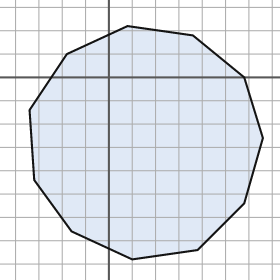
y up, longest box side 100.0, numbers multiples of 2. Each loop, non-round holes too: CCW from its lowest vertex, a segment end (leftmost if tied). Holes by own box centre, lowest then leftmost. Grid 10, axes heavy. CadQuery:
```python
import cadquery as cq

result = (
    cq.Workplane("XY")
    .moveTo(10.0, -78.0)
    .lineTo(38.0, -74.0)
    .lineTo(58.0, -54.0)
    .lineTo(66.0, -26.0)
    .lineTo(58.0, 0.0)
    .lineTo(36.0, 18.0)
    .lineTo(8.0, 22.0)
    .lineTo(-18.0, 10.0)
    .lineTo(-34.0, -14.0)
    .lineTo(-32.0, -44.0)
    .lineTo(-16.0, -66.0)
    .close()
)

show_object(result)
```